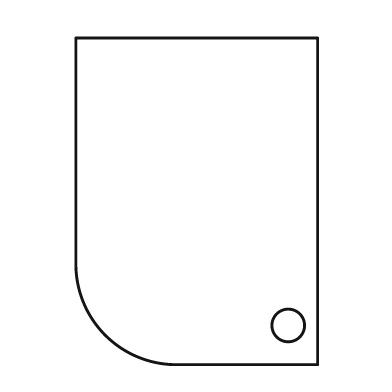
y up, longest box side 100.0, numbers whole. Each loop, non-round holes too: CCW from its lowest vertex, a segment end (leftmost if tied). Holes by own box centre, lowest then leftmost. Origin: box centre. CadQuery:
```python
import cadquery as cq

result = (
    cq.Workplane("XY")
    .moveTo(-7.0, -50.0)
    .lineTo(37.0, -50.0)
    .lineTo(37.0, 50.0)
    .lineTo(-37.0, 50.0)
    .lineTo(-37.0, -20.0)
    .threePointArc((-28.0, -41.0), (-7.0, -50.0))
    .close()
    .moveTo(28.0, -38.0)
    .circle(5.0)
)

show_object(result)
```